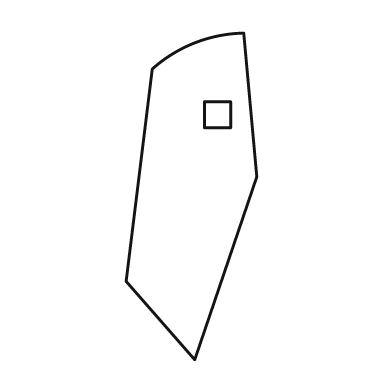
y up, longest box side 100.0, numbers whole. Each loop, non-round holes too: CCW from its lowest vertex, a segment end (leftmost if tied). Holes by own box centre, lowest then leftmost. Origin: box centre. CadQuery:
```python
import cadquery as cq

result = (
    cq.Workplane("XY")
    .moveTo(1.0, -50.0)
    .lineTo(20.0, 6.0)
    .lineTo(16.0, 50.0)
    .threePointArc((1.0, 47.0), (-12.0, 39.0))
    .lineTo(-20.0, -26.0)
    .close()
    .moveTo(4.0, 21.0)
    .lineTo(12.0, 21.0)
    .lineTo(12.0, 29.0)
    .lineTo(4.0, 29.0)
    .close()
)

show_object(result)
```